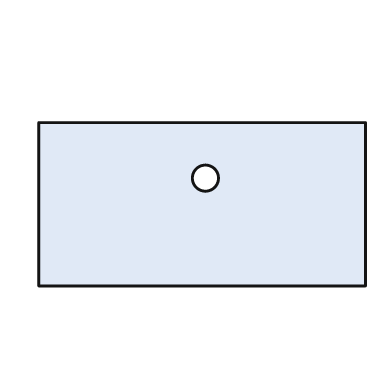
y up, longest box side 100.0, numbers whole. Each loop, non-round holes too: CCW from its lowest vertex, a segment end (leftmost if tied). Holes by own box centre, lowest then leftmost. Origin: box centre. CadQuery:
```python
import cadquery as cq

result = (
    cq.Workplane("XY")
    .moveTo(-50.0, -25.0)
    .lineTo(50.0, -25.0)
    .lineTo(50.0, 25.0)
    .lineTo(-50.0, 25.0)
    .close()
    .moveTo(1.0, 8.0)
    .circle(4.0)
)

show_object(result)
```